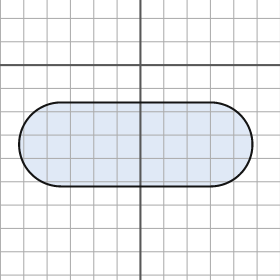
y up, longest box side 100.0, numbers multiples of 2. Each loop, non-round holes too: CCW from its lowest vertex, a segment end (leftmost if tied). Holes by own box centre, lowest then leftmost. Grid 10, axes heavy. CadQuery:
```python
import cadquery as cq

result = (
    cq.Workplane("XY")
    .moveTo(-34.0, -52.0)
    .lineTo(30.0, -52.0)
    .threePointArc((48.0, -34.0), (30.0, -16.0))
    .lineTo(-34.0, -16.0)
    .threePointArc((-52.0, -34.0), (-34.0, -52.0))
    .close()
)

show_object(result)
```